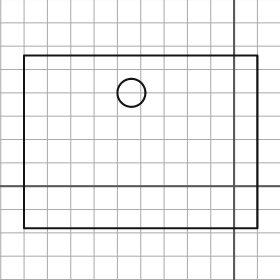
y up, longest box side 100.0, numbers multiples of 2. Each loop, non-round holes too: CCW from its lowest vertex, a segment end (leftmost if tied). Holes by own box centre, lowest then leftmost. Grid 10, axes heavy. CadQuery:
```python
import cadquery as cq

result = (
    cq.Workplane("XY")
    .moveTo(-90.0, -18.0)
    .lineTo(10.0, -18.0)
    .lineTo(10.0, 56.0)
    .lineTo(-90.0, 56.0)
    .close()
    .moveTo(-44.0, 40.0)
    .circle(6.0)
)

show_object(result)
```